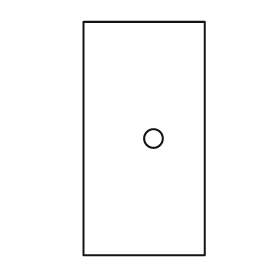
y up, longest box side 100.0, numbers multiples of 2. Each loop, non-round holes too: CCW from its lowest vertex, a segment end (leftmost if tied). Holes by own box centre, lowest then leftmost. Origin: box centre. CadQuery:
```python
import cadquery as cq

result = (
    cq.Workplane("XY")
    .moveTo(-26.0, -50.0)
    .lineTo(26.0, -50.0)
    .lineTo(26.0, 50.0)
    .lineTo(-26.0, 50.0)
    .close()
    .moveTo(4.0, 0.0)
    .circle(4.0)
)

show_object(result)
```